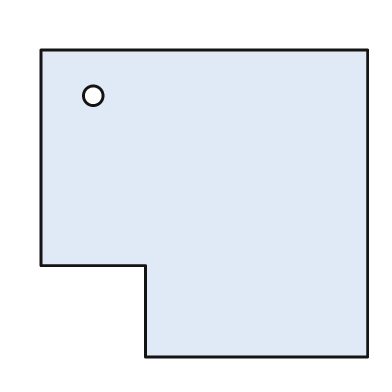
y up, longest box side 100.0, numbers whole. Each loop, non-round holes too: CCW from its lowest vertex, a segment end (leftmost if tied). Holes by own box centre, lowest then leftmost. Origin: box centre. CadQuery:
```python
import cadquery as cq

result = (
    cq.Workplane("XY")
    .moveTo(-18.0, -47.0)
    .lineTo(50.0, -47.0)
    .lineTo(50.0, 47.0)
    .lineTo(-50.0, 47.0)
    .lineTo(-50.0, -19.0)
    .lineTo(-18.0, -19.0)
    .close()
    .moveTo(-34.0, 33.0)
    .circle(3.0)
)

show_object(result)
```